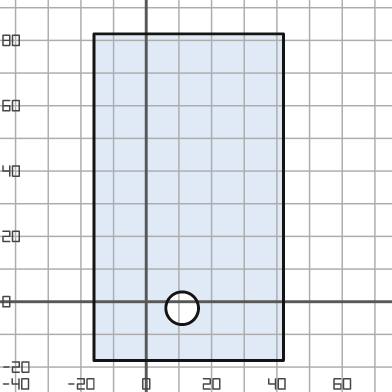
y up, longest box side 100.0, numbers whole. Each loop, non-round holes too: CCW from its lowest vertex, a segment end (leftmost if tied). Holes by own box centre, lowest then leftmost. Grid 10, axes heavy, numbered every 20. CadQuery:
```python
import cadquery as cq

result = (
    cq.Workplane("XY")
    .moveTo(-16.0, -18.0)
    .lineTo(42.0, -18.0)
    .lineTo(42.0, 82.0)
    .lineTo(-16.0, 82.0)
    .close()
    .moveTo(11.0, -2.0)
    .circle(5.0)
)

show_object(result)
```